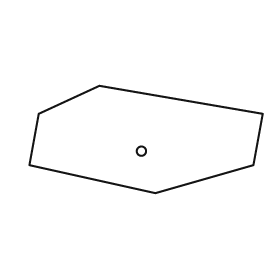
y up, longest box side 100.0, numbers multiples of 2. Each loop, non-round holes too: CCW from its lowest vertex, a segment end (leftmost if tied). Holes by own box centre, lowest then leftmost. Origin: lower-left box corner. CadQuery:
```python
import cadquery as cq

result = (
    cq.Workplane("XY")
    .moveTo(54.0, 0.0)
    .lineTo(96.0, 12.0)
    .lineTo(100.0, 34.0)
    .lineTo(30.0, 46.0)
    .lineTo(4.0, 34.0)
    .lineTo(0.0, 12.0)
    .close()
    .moveTo(48.0, 18.0)
    .circle(2.0)
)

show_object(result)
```